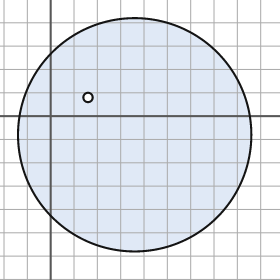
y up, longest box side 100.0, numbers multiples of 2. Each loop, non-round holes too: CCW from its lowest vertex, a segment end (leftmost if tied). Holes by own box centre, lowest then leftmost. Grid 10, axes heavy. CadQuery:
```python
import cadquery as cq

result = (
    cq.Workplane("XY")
    .moveTo(36.0, -8.0)
    .circle(50.0)
    .moveTo(16.0, 8.0)
    .circle(2.0)
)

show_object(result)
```